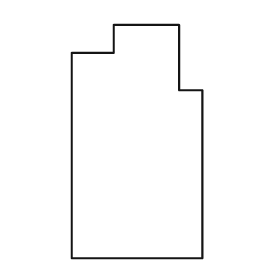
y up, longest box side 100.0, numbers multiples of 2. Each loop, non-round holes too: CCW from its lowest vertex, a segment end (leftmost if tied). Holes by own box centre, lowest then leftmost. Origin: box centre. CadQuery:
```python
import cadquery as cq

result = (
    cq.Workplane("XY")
    .moveTo(-28.0, -50.0)
    .lineTo(28.0, -50.0)
    .lineTo(28.0, 22.0)
    .lineTo(18.0, 22.0)
    .lineTo(18.0, 50.0)
    .lineTo(-10.0, 50.0)
    .lineTo(-10.0, 38.0)
    .lineTo(-28.0, 38.0)
    .close()
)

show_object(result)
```